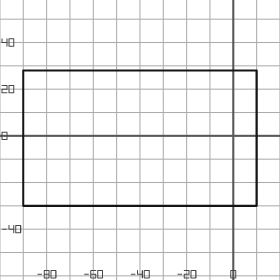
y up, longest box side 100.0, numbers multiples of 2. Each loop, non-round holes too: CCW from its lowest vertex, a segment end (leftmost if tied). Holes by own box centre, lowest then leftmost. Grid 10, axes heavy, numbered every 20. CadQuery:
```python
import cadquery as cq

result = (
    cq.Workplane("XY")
    .moveTo(-90.0, -30.0)
    .lineTo(10.0, -30.0)
    .lineTo(10.0, 28.0)
    .lineTo(-90.0, 28.0)
    .close()
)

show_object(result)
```